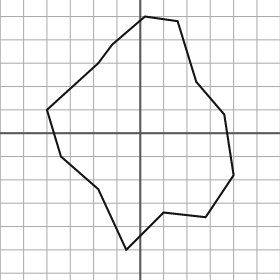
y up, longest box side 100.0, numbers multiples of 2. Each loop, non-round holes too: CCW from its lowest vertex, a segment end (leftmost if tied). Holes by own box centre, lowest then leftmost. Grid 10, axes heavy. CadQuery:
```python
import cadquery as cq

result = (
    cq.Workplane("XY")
    .moveTo(-6.0, -50.0)
    .lineTo(10.0, -34.0)
    .lineTo(28.0, -36.0)
    .lineTo(40.0, -18.0)
    .lineTo(36.0, 8.0)
    .lineTo(24.0, 22.0)
    .lineTo(16.0, 48.0)
    .lineTo(2.0, 50.0)
    .lineTo(-12.0, 38.0)
    .lineTo(-18.0, 30.0)
    .lineTo(-40.0, 10.0)
    .lineTo(-34.0, -10.0)
    .lineTo(-18.0, -24.0)
    .close()
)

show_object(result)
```